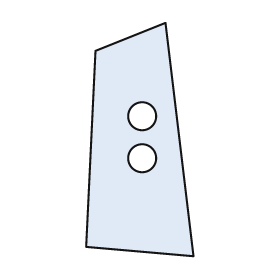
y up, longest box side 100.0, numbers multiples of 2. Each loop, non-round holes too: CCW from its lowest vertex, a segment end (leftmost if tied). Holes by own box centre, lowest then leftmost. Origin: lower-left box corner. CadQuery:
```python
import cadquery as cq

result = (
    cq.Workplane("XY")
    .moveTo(46.0, 0.0)
    .lineTo(34.0, 100.0)
    .lineTo(4.0, 88.0)
    .lineTo(0.0, 4.0)
    .close()
    .moveTo(24.0, 42.0)
    .circle(6.0)
    .moveTo(24.0, 60.0)
    .circle(6.0)
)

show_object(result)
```